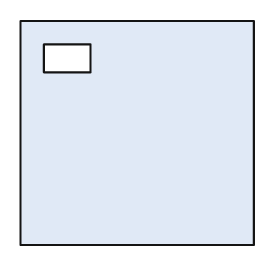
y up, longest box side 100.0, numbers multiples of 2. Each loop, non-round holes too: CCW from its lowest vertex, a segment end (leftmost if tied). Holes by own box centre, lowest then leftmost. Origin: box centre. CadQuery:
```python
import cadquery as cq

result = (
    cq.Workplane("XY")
    .moveTo(-50.0, -48.0)
    .lineTo(50.0, -48.0)
    .lineTo(50.0, 48.0)
    .lineTo(-50.0, 48.0)
    .close()
    .moveTo(-40.0, 26.0)
    .lineTo(-20.0, 26.0)
    .lineTo(-20.0, 38.0)
    .lineTo(-40.0, 38.0)
    .close()
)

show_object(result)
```